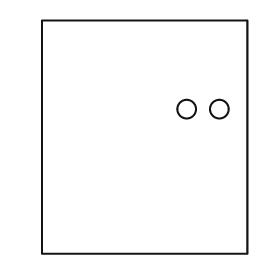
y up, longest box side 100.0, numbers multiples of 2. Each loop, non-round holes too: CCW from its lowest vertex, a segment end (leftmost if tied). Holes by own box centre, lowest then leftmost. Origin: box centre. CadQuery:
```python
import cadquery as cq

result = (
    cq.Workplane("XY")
    .moveTo(-44.0, -50.0)
    .lineTo(44.0, -50.0)
    .lineTo(44.0, 50.0)
    .lineTo(-44.0, 50.0)
    .close()
    .moveTo(18.0, 12.0)
    .circle(4.0)
    .moveTo(32.0, 12.0)
    .circle(4.0)
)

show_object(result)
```